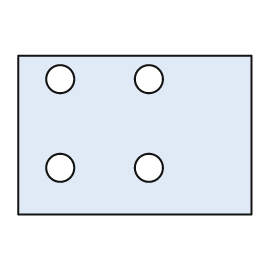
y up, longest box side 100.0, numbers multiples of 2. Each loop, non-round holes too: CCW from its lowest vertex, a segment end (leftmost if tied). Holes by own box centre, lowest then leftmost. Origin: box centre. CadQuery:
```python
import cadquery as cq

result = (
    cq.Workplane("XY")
    .moveTo(-50.0, -34.0)
    .lineTo(50.0, -34.0)
    .lineTo(50.0, 34.0)
    .lineTo(-50.0, 34.0)
    .close()
    .moveTo(-32.0, -14.0)
    .circle(6.0)
    .moveTo(6.0, -14.0)
    .circle(6.0)
    .moveTo(-32.0, 24.0)
    .circle(6.0)
    .moveTo(6.0, 24.0)
    .circle(6.0)
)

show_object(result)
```